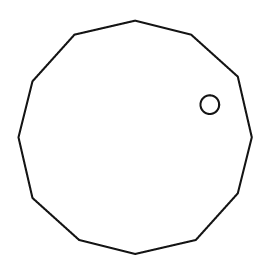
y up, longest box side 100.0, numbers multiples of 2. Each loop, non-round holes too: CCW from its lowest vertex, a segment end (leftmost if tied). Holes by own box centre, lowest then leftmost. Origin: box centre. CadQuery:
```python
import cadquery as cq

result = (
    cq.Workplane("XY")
    .moveTo(0.0, -50.0)
    .lineTo(26.0, -44.0)
    .lineTo(44.0, -24.0)
    .lineTo(50.0, 0.0)
    .lineTo(44.0, 26.0)
    .lineTo(24.0, 44.0)
    .lineTo(0.0, 50.0)
    .lineTo(-26.0, 44.0)
    .lineTo(-44.0, 24.0)
    .lineTo(-50.0, 0.0)
    .lineTo(-44.0, -26.0)
    .lineTo(-24.0, -44.0)
    .close()
    .moveTo(32.0, 14.0)
    .circle(4.0)
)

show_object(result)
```